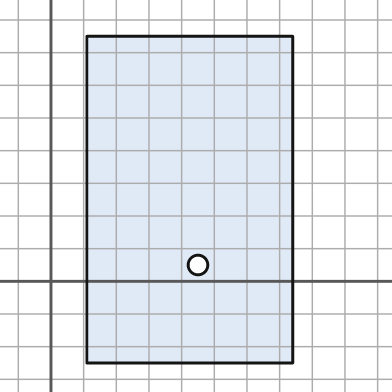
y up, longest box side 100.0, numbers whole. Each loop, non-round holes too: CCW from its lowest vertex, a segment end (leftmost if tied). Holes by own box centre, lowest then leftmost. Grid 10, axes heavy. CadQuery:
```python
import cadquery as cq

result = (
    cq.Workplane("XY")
    .moveTo(11.0, -25.0)
    .lineTo(74.0, -25.0)
    .lineTo(74.0, 75.0)
    .lineTo(11.0, 75.0)
    .close()
    .moveTo(45.0, 5.0)
    .circle(3.0)
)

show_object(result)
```